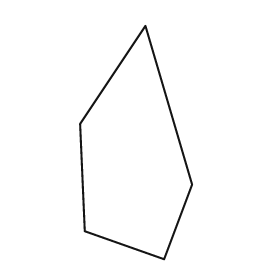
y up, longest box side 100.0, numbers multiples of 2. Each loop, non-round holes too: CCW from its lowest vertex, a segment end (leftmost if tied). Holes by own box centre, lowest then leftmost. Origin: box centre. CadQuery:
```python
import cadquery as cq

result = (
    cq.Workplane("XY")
    .moveTo(12.0, -50.0)
    .lineTo(24.0, -18.0)
    .lineTo(4.0, 50.0)
    .lineTo(-24.0, 8.0)
    .lineTo(-22.0, -38.0)
    .close()
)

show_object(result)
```